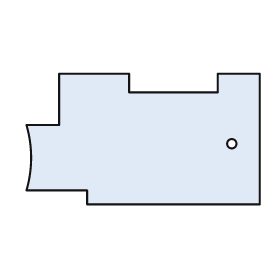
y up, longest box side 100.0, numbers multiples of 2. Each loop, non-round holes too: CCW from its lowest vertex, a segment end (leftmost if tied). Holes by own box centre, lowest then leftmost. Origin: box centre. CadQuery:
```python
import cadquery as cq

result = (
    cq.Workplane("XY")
    .moveTo(-24.0, -28.0)
    .lineTo(50.0, -28.0)
    .lineTo(50.0, 28.0)
    .lineTo(32.0, 28.0)
    .lineTo(32.0, 20.0)
    .lineTo(-6.0, 20.0)
    .lineTo(-6.0, 28.0)
    .lineTo(-36.0, 28.0)
    .lineTo(-36.0, 6.0)
    .lineTo(-50.0, 6.0)
    .threePointArc((-48.0, -8.0), (-50.0, -22.0))
    .lineTo(-24.0, -22.0)
    .close()
    .moveTo(38.0, -2.0)
    .circle(2.0)
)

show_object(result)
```